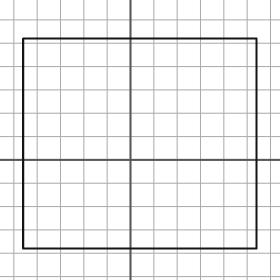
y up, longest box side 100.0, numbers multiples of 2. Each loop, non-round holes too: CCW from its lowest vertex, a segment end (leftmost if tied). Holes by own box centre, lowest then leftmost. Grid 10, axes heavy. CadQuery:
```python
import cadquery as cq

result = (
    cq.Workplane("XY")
    .moveTo(-46.0, -38.0)
    .lineTo(54.0, -38.0)
    .lineTo(54.0, 52.0)
    .lineTo(-46.0, 52.0)
    .close()
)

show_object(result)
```